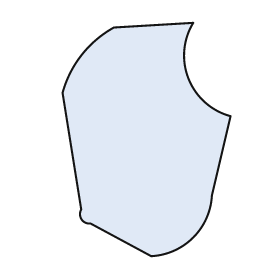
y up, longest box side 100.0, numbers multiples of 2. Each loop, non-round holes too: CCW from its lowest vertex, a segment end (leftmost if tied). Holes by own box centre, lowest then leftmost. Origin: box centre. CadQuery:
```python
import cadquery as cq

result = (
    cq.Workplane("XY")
    .moveTo(2.0, -50.0)
    .threePointArc((20.0, -42.0), (28.0, -24.0))
    .lineTo(36.0, 10.0)
    .threePointArc((18.0, 26.0), (20.0, 50.0))
    .lineTo(-14.0, 48.0)
    .threePointArc((-28.0, 36.0), (-36.0, 20.0))
    .lineTo(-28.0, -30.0)
    .threePointArc((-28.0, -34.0), (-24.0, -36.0))
    .close()
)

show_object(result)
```